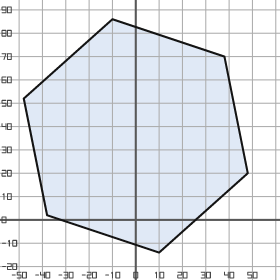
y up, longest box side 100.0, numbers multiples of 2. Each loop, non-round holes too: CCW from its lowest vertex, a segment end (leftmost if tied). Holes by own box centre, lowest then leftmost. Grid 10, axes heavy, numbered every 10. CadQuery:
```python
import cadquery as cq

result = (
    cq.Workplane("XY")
    .moveTo(10.0, -14.0)
    .lineTo(48.0, 20.0)
    .lineTo(38.0, 70.0)
    .lineTo(-10.0, 86.0)
    .lineTo(-48.0, 52.0)
    .lineTo(-38.0, 2.0)
    .close()
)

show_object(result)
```